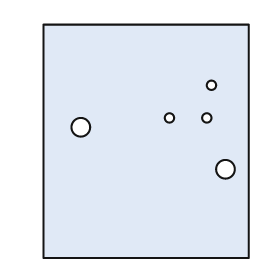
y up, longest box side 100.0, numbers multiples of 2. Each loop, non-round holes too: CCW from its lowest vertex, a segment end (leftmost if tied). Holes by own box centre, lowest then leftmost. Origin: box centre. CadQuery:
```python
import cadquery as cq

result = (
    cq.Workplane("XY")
    .moveTo(-44.0, -50.0)
    .lineTo(44.0, -50.0)
    .lineTo(44.0, 50.0)
    .lineTo(-44.0, 50.0)
    .close()
    .moveTo(34.0, -12.0)
    .circle(4.0)
    .moveTo(-28.0, 6.0)
    .circle(4.0)
    .moveTo(10.0, 10.0)
    .circle(2.0)
    .moveTo(26.0, 10.0)
    .circle(2.0)
    .moveTo(28.0, 24.0)
    .circle(2.0)
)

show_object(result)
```